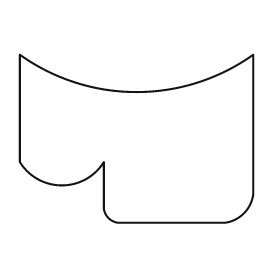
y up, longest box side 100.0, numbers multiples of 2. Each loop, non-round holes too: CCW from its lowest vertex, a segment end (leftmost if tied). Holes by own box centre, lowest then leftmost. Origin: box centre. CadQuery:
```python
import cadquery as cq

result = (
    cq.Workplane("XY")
    .moveTo(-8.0, -36.0)
    .lineTo(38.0, -36.0)
    .threePointArc((46.0, -32.0), (50.0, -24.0))
    .lineTo(50.0, 36.0)
    .threePointArc((0.0, 20.0), (-50.0, 36.0))
    .lineTo(-50.0, -10.0)
    .threePointArc((-32.0, -20.0), (-14.0, -10.0))
    .lineTo(-14.0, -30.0)
    .threePointArc((-12.0, -34.0), (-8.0, -36.0))
    .close()
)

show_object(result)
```